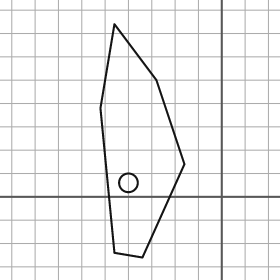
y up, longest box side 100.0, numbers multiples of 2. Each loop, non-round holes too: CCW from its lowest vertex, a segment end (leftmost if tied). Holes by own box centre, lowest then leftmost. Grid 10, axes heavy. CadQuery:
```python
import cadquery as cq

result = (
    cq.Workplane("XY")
    .moveTo(-34.0, -26.0)
    .lineTo(-16.0, 14.0)
    .lineTo(-28.0, 50.0)
    .lineTo(-46.0, 74.0)
    .lineTo(-52.0, 38.0)
    .lineTo(-46.0, -24.0)
    .close()
    .moveTo(-40.0, 6.0)
    .circle(4.0)
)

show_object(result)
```